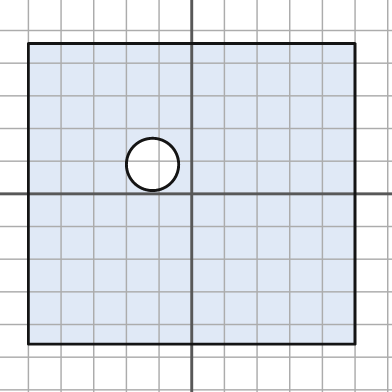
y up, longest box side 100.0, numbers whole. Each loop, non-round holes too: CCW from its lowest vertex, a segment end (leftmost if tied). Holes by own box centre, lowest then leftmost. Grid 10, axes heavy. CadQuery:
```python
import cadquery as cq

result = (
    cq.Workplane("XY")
    .moveTo(-50.0, -46.0)
    .lineTo(50.0, -46.0)
    .lineTo(50.0, 46.0)
    .lineTo(-50.0, 46.0)
    .close()
    .moveTo(-12.0, 9.0)
    .circle(8.0)
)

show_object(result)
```